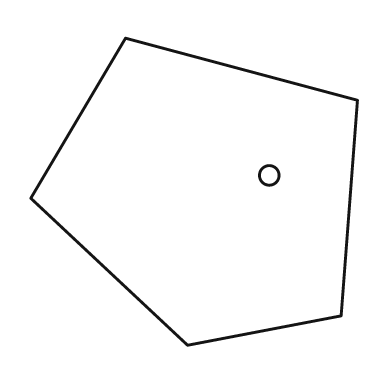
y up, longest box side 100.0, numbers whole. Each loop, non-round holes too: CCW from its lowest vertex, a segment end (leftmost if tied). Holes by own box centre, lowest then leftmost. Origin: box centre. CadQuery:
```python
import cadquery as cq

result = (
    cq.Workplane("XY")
    .moveTo(-2.0, -47.0)
    .lineTo(45.0, -38.0)
    .lineTo(50.0, 28.0)
    .lineTo(-21.0, 47.0)
    .lineTo(-50.0, -2.0)
    .close()
    .moveTo(23.0, 5.0)
    .circle(3.0)
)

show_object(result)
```